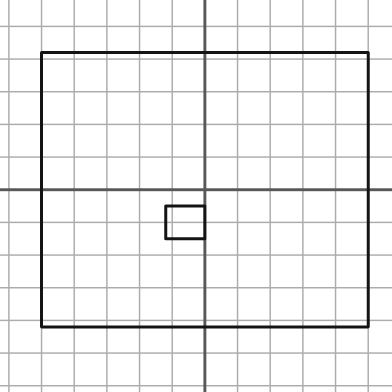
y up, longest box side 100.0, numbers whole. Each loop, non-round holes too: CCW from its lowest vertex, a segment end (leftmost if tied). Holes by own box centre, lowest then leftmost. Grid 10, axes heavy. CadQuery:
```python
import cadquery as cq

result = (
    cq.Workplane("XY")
    .moveTo(-50.0, -42.0)
    .lineTo(50.0, -42.0)
    .lineTo(50.0, 42.0)
    .lineTo(-50.0, 42.0)
    .close()
    .moveTo(-12.0, -15.0)
    .lineTo(0.0, -15.0)
    .lineTo(0.0, -5.0)
    .lineTo(-12.0, -5.0)
    .close()
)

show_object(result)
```